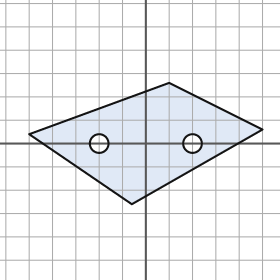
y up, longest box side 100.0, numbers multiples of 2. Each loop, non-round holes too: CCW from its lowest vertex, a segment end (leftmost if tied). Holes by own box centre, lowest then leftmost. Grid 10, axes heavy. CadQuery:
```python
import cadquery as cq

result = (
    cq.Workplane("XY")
    .moveTo(-6.0, -26.0)
    .lineTo(50.0, 6.0)
    .lineTo(10.0, 26.0)
    .lineTo(-50.0, 4.0)
    .close()
    .moveTo(-20.0, 0.0)
    .circle(4.0)
    .moveTo(20.0, 0.0)
    .circle(4.0)
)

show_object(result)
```